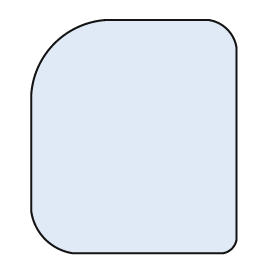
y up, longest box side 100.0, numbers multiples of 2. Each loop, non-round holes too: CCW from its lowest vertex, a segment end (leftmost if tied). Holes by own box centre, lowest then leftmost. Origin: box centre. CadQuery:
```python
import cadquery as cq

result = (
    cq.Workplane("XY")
    .moveTo(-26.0, -50.0)
    .lineTo(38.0, -50.0)
    .threePointArc((42.0, -48.0), (44.0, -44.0))
    .lineTo(44.0, 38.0)
    .threePointArc((40.0, 46.0), (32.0, 50.0))
    .lineTo(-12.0, 50.0)
    .threePointArc((-34.0, 40.0), (-44.0, 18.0))
    .lineTo(-44.0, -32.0)
    .threePointArc((-38.0, -44.0), (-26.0, -50.0))
    .close()
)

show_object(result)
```